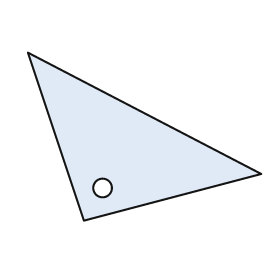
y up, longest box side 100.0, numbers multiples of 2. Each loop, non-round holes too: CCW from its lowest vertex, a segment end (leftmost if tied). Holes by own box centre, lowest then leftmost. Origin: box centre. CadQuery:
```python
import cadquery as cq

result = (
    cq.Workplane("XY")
    .moveTo(-26.0, -36.0)
    .lineTo(50.0, -16.0)
    .lineTo(-50.0, 36.0)
    .close()
    .moveTo(-18.0, -22.0)
    .circle(4.0)
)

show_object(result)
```